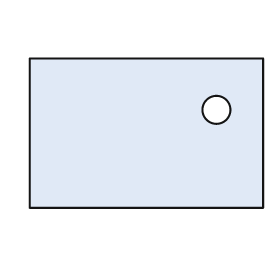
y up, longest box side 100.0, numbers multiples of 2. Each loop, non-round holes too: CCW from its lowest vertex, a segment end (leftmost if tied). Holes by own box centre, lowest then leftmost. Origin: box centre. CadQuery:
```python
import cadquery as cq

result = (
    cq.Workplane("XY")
    .moveTo(-50.0, -32.0)
    .lineTo(50.0, -32.0)
    .lineTo(50.0, 32.0)
    .lineTo(-50.0, 32.0)
    .close()
    .moveTo(30.0, 10.0)
    .circle(6.0)
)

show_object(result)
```